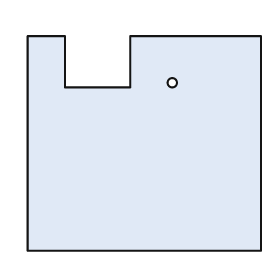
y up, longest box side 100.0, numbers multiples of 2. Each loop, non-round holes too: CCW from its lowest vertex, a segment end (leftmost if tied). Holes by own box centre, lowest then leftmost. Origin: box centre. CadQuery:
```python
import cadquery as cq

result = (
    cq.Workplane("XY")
    .moveTo(-50.0, -46.0)
    .lineTo(50.0, -46.0)
    .lineTo(50.0, 46.0)
    .lineTo(-6.0, 46.0)
    .lineTo(-6.0, 24.0)
    .lineTo(-34.0, 24.0)
    .lineTo(-34.0, 46.0)
    .lineTo(-50.0, 46.0)
    .close()
    .moveTo(12.0, 26.0)
    .circle(2.0)
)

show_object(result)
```